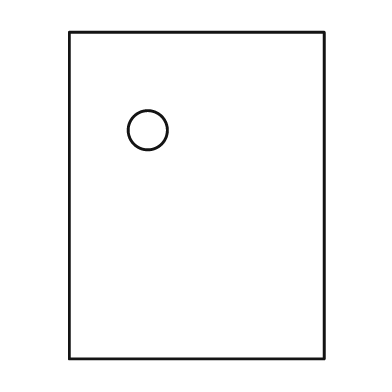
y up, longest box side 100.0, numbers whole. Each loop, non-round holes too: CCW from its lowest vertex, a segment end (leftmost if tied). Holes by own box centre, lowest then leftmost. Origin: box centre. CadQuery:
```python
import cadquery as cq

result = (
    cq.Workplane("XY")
    .moveTo(-39.0, -50.0)
    .lineTo(39.0, -50.0)
    .lineTo(39.0, 50.0)
    .lineTo(-39.0, 50.0)
    .close()
    .moveTo(-15.0, 20.0)
    .circle(6.0)
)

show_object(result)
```